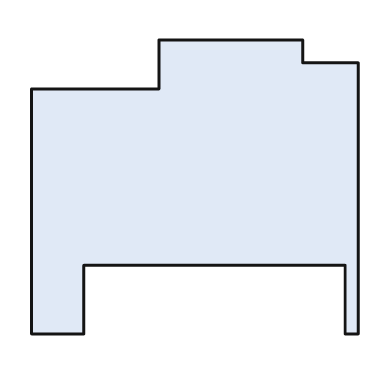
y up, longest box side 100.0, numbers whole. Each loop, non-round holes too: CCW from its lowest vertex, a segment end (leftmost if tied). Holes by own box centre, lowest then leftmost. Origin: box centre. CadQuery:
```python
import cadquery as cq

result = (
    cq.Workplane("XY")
    .moveTo(-50.0, -45.0)
    .lineTo(-34.0, -45.0)
    .lineTo(-34.0, -24.0)
    .lineTo(46.0, -24.0)
    .lineTo(46.0, -45.0)
    .lineTo(50.0, -45.0)
    .lineTo(50.0, 38.0)
    .lineTo(33.0, 38.0)
    .lineTo(33.0, 45.0)
    .lineTo(-11.0, 45.0)
    .lineTo(-11.0, 30.0)
    .lineTo(-50.0, 30.0)
    .close()
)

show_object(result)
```